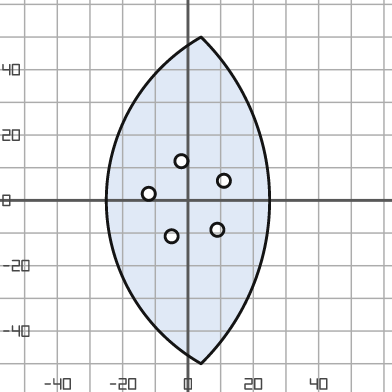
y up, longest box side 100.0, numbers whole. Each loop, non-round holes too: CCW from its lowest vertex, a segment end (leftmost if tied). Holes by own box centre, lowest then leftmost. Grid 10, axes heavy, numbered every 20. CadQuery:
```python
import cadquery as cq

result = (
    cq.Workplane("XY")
    .moveTo(4.0, -50.0)
    .threePointArc((25.0, 0.0), (4.0, 50.0))
    .threePointArc((-25.0, 0.0), (4.0, -50.0))
    .close()
    .moveTo(-5.0, -11.0)
    .circle(2.0)
    .moveTo(9.0, -9.0)
    .circle(2.0)
    .moveTo(-12.0, 2.0)
    .circle(2.0)
    .moveTo(11.0, 6.0)
    .circle(2.0)
    .moveTo(-2.0, 12.0)
    .circle(2.0)
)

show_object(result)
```